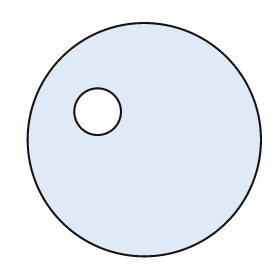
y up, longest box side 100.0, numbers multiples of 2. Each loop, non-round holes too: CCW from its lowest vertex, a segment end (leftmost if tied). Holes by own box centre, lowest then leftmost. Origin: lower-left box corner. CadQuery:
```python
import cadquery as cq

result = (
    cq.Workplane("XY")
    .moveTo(50.0, 50.0)
    .circle(50.0)
    .moveTo(30.0, 62.0)
    .circle(10.0)
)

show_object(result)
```